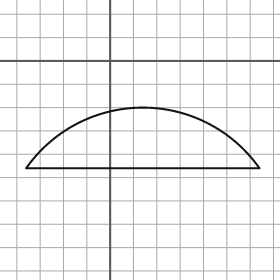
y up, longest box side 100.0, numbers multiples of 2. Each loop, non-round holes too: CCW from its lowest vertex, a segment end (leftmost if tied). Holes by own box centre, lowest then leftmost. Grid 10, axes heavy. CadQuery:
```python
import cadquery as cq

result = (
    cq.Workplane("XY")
    .moveTo(-36.0, -46.0)
    .lineTo(64.0, -46.0)
    .threePointArc((14.0, -20.0), (-36.0, -46.0))
    .close()
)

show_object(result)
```